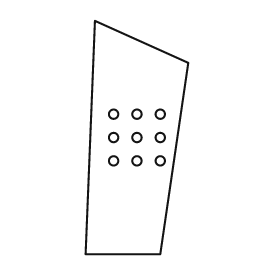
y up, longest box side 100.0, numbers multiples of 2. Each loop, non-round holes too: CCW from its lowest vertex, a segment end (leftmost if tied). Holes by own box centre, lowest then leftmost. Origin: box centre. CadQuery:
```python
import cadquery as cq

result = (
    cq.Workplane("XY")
    .moveTo(-22.0, -50.0)
    .lineTo(10.0, -50.0)
    .lineTo(22.0, 32.0)
    .lineTo(-18.0, 50.0)
    .close()
    .moveTo(-10.0, -10.0)
    .circle(2.0)
    .moveTo(0.0, -10.0)
    .circle(2.0)
    .moveTo(10.0, -10.0)
    .circle(2.0)
    .moveTo(-10.0, 0.0)
    .circle(2.0)
    .moveTo(0.0, 0.0)
    .circle(2.0)
    .moveTo(10.0, 0.0)
    .circle(2.0)
    .moveTo(-10.0, 10.0)
    .circle(2.0)
    .moveTo(0.0, 10.0)
    .circle(2.0)
    .moveTo(10.0, 10.0)
    .circle(2.0)
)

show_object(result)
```